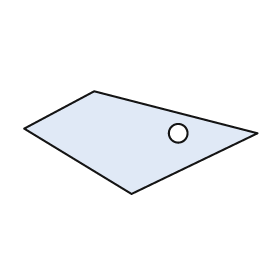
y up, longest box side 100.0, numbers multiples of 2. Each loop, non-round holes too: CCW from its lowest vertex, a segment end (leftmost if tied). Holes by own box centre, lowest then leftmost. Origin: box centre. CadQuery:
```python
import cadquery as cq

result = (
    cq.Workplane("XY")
    .moveTo(-4.0, -22.0)
    .lineTo(50.0, 4.0)
    .lineTo(-20.0, 22.0)
    .lineTo(-50.0, 6.0)
    .close()
    .moveTo(16.0, 4.0)
    .circle(4.0)
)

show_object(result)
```